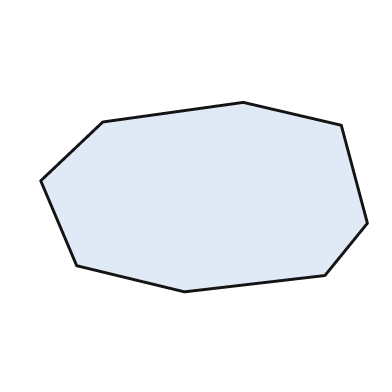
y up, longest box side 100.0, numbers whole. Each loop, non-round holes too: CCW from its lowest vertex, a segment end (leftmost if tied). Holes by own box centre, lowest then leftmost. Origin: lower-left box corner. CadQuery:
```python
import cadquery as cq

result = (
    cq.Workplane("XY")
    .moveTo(44.0, 0.0)
    .lineTo(87.0, 5.0)
    .lineTo(100.0, 21.0)
    .lineTo(92.0, 51.0)
    .lineTo(62.0, 58.0)
    .lineTo(19.0, 52.0)
    .lineTo(0.0, 34.0)
    .lineTo(11.0, 8.0)
    .close()
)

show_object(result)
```